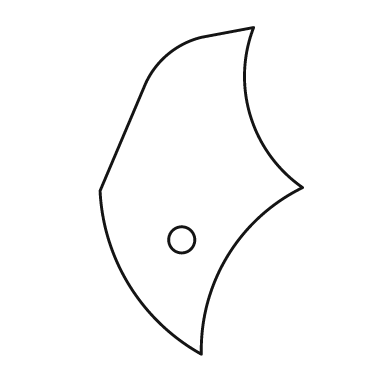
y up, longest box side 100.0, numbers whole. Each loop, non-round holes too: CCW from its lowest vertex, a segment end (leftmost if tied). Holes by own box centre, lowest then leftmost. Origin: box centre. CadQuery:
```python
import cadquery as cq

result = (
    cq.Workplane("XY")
    .moveTo(0.0, -50.0)
    .threePointArc((8.0, -20.0), (31.0, 1.0))
    .threePointArc((15.0, 23.0), (16.0, 50.0))
    .lineTo(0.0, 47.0)
    .threePointArc((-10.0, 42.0), (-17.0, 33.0))
    .lineTo(-31.0, 0.0)
    .threePointArc((-22.0, -29.0), (0.0, -50.0))
    .close()
    .moveTo(-6.0, -15.0)
    .circle(4.0)
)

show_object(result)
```